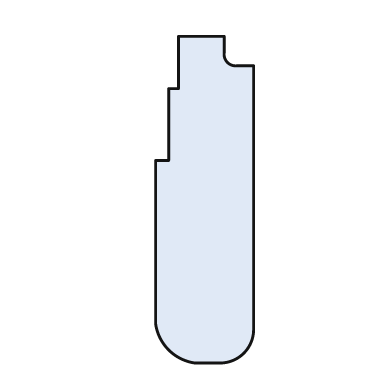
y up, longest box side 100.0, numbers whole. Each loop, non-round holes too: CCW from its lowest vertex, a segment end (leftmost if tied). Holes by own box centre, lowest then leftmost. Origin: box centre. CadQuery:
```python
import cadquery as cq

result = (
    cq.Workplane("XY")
    .moveTo(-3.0, -50.0)
    .lineTo(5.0, -50.0)
    .threePointArc((12.0, -47.0), (15.0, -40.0))
    .lineTo(15.0, 41.0)
    .lineTo(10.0, 41.0)
    .threePointArc((7.0, 42.0), (6.0, 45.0))
    .lineTo(6.0, 50.0)
    .lineTo(-8.0, 50.0)
    .lineTo(-8.0, 34.0)
    .lineTo(-11.0, 34.0)
    .lineTo(-11.0, 12.0)
    .lineTo(-15.0, 12.0)
    .lineTo(-15.0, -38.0)
    .threePointArc((-11.0, -46.0), (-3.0, -50.0))
    .close()
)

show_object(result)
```